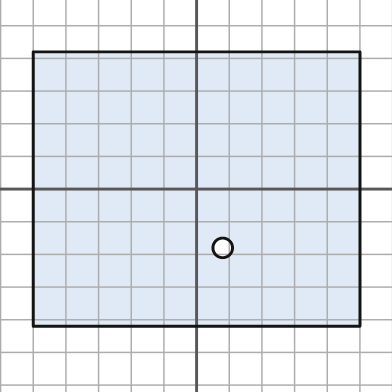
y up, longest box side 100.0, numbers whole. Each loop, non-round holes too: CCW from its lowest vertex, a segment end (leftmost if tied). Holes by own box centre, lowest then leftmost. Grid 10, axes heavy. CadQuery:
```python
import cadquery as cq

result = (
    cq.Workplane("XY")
    .moveTo(-50.0, -42.0)
    .lineTo(50.0, -42.0)
    .lineTo(50.0, 42.0)
    .lineTo(-50.0, 42.0)
    .close()
    .moveTo(8.0, -18.0)
    .circle(3.0)
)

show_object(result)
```